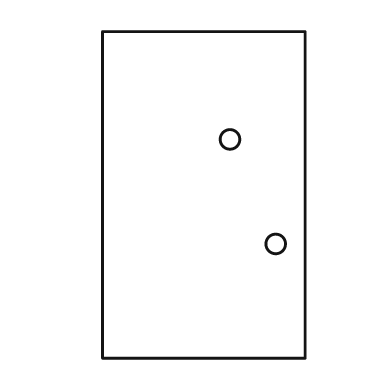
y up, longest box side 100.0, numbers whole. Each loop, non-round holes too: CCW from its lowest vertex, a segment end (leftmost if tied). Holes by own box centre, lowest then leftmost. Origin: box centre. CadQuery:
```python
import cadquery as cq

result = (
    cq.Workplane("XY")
    .moveTo(-31.0, -50.0)
    .lineTo(31.0, -50.0)
    .lineTo(31.0, 50.0)
    .lineTo(-31.0, 50.0)
    .close()
    .moveTo(22.0, -15.0)
    .circle(3.0)
    .moveTo(8.0, 17.0)
    .circle(3.0)
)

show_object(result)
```